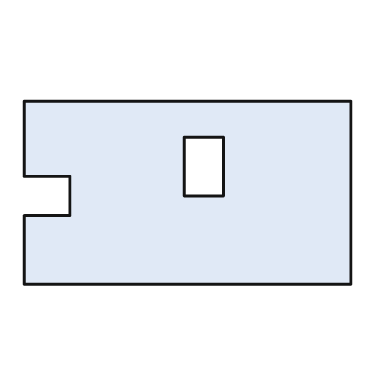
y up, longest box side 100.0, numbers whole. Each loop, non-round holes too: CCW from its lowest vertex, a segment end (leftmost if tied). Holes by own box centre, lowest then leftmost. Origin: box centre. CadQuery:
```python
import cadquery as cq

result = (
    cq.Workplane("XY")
    .moveTo(-50.0, -28.0)
    .lineTo(50.0, -28.0)
    .lineTo(50.0, 28.0)
    .lineTo(-50.0, 28.0)
    .lineTo(-50.0, 5.0)
    .lineTo(-36.0, 5.0)
    .lineTo(-36.0, -7.0)
    .lineTo(-50.0, -7.0)
    .close()
    .moveTo(-1.0, -1.0)
    .lineTo(11.0, -1.0)
    .lineTo(11.0, 17.0)
    .lineTo(-1.0, 17.0)
    .close()
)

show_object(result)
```